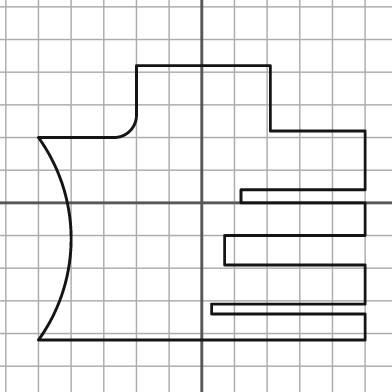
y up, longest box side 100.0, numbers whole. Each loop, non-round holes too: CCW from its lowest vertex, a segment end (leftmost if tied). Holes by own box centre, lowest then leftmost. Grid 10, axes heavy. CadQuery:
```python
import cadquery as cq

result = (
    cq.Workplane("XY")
    .moveTo(-50.0, -42.0)
    .lineTo(50.0, -42.0)
    .lineTo(50.0, -34.0)
    .lineTo(3.0, -34.0)
    .lineTo(3.0, -31.0)
    .lineTo(50.0, -31.0)
    .lineTo(50.0, -19.0)
    .lineTo(7.0, -19.0)
    .lineTo(7.0, -10.0)
    .lineTo(50.0, -10.0)
    .lineTo(50.0, 0.0)
    .lineTo(12.0, 0.0)
    .lineTo(12.0, 4.0)
    .lineTo(50.0, 4.0)
    .lineTo(50.0, 22.0)
    .lineTo(21.0, 22.0)
    .lineTo(21.0, 42.0)
    .lineTo(-20.0, 42.0)
    .lineTo(-20.0, 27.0)
    .threePointArc((-22.0, 22.0), (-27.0, 20.0))
    .lineTo(-50.0, 20.0)
    .threePointArc((-40.0, -11.0), (-50.0, -42.0))
    .close()
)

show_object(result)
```